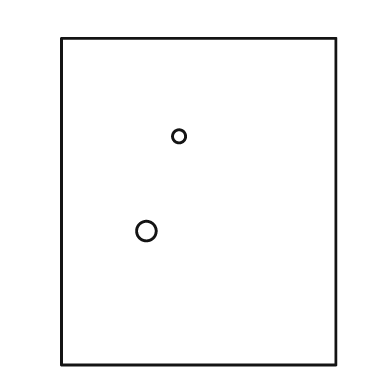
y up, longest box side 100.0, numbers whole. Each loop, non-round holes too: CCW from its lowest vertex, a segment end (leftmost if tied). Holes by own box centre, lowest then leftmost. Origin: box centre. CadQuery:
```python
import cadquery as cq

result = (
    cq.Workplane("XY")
    .moveTo(-42.0, -50.0)
    .lineTo(42.0, -50.0)
    .lineTo(42.0, 50.0)
    .lineTo(-42.0, 50.0)
    .close()
    .moveTo(-16.0, -9.0)
    .circle(3.0)
    .moveTo(-6.0, 20.0)
    .circle(2.0)
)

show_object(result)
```